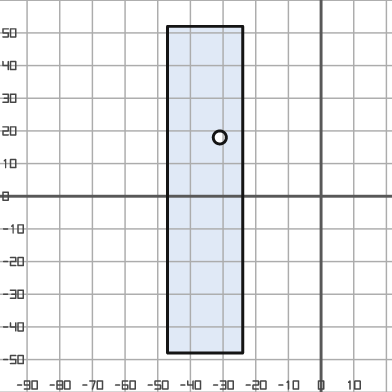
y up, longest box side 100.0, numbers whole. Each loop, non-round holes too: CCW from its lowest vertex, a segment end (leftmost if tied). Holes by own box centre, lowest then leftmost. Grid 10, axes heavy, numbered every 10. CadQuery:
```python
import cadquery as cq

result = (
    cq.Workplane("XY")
    .moveTo(-47.0, -48.0)
    .lineTo(-24.0, -48.0)
    .lineTo(-24.0, 52.0)
    .lineTo(-47.0, 52.0)
    .close()
    .moveTo(-31.0, 18.0)
    .circle(2.0)
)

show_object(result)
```